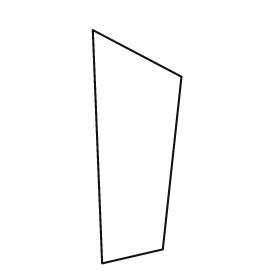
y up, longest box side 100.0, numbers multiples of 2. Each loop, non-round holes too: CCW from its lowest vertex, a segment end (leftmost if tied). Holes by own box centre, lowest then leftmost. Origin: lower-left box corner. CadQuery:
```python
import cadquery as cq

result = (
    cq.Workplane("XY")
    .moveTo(4.0, 0.0)
    .lineTo(30.0, 6.0)
    .lineTo(38.0, 80.0)
    .lineTo(0.0, 100.0)
    .close()
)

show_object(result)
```